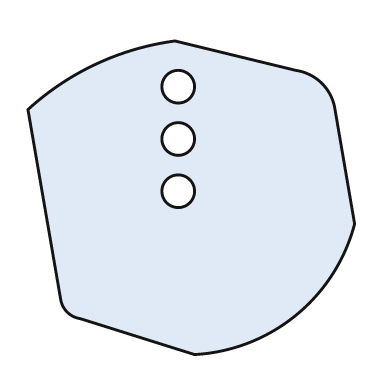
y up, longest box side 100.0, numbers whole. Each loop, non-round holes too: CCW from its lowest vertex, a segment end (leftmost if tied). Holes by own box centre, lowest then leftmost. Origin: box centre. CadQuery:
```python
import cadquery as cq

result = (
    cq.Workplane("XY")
    .moveTo(1.0, -48.0)
    .threePointArc((32.0, -36.0), (50.0, -8.0))
    .lineTo(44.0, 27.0)
    .threePointArc((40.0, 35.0), (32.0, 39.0))
    .lineTo(-5.0, 48.0)
    .threePointArc((-29.0, 41.0), (-50.0, 27.0))
    .lineTo(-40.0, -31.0)
    .threePointArc((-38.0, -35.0), (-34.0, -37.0))
    .close()
    .moveTo(-4.0, 2.0)
    .circle(5.0)
    .moveTo(-4.0, 18.0)
    .circle(5.0)
    .moveTo(-4.0, 34.0)
    .circle(5.0)
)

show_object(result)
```